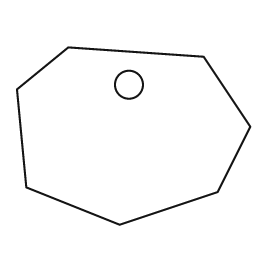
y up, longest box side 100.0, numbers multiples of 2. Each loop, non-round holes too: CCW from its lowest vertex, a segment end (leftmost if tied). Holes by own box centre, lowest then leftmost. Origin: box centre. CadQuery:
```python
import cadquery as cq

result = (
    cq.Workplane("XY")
    .moveTo(-6.0, -38.0)
    .lineTo(36.0, -24.0)
    .lineTo(50.0, 4.0)
    .lineTo(30.0, 34.0)
    .lineTo(-28.0, 38.0)
    .lineTo(-50.0, 20.0)
    .lineTo(-46.0, -22.0)
    .close()
    .moveTo(-2.0, 22.0)
    .circle(6.0)
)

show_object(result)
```